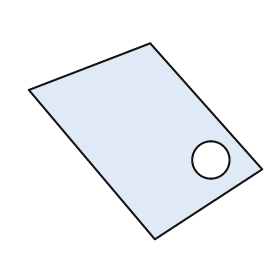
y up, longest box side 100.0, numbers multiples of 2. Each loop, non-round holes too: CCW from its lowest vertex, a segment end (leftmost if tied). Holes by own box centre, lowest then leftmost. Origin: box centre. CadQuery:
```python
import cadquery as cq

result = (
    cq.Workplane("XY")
    .moveTo(4.0, -42.0)
    .lineTo(50.0, -12.0)
    .lineTo(2.0, 42.0)
    .lineTo(-50.0, 22.0)
    .close()
    .moveTo(28.0, -8.0)
    .circle(8.0)
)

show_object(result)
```